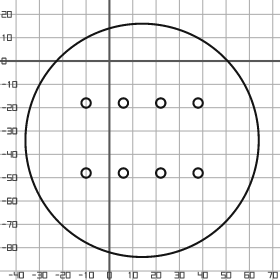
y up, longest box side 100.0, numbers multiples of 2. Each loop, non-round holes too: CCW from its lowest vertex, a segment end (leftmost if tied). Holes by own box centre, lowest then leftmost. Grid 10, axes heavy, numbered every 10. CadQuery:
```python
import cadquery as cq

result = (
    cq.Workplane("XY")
    .moveTo(14.0, -34.0)
    .circle(50.0)
    .moveTo(-10.0, -48.0)
    .circle(2.0)
    .moveTo(6.0, -48.0)
    .circle(2.0)
    .moveTo(22.0, -48.0)
    .circle(2.0)
    .moveTo(38.0, -48.0)
    .circle(2.0)
    .moveTo(-10.0, -18.0)
    .circle(2.0)
    .moveTo(6.0, -18.0)
    .circle(2.0)
    .moveTo(22.0, -18.0)
    .circle(2.0)
    .moveTo(38.0, -18.0)
    .circle(2.0)
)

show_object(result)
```